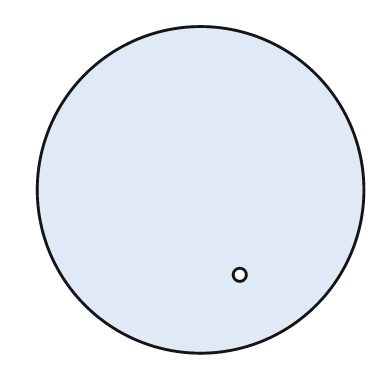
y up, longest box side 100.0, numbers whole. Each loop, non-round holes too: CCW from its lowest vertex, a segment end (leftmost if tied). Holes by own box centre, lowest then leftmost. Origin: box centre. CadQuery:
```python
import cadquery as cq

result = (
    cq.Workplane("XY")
    .moveTo(0.0, 0.0)
    .circle(50.0)
    .moveTo(12.0, -26.0)
    .circle(2.0)
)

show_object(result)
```